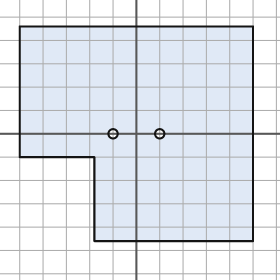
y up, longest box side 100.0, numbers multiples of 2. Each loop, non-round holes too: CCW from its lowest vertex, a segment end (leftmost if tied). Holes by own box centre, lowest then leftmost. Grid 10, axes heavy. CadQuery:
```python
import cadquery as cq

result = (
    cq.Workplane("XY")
    .moveTo(-18.0, -46.0)
    .lineTo(50.0, -46.0)
    .lineTo(50.0, 46.0)
    .lineTo(-50.0, 46.0)
    .lineTo(-50.0, -10.0)
    .lineTo(-18.0, -10.0)
    .close()
    .moveTo(-10.0, 0.0)
    .circle(2.0)
    .moveTo(10.0, 0.0)
    .circle(2.0)
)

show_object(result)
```